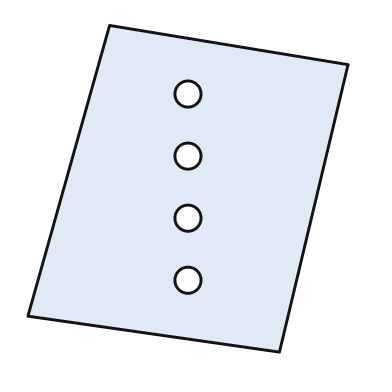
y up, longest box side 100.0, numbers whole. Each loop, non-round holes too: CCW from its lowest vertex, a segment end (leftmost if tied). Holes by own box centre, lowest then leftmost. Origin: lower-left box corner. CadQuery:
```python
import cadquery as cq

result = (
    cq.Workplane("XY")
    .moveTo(77.0, 0.0)
    .lineTo(98.0, 88.0)
    .lineTo(25.0, 100.0)
    .lineTo(0.0, 11.0)
    .close()
    .moveTo(49.0, 22.0)
    .circle(4.0)
    .moveTo(49.0, 41.0)
    .circle(4.0)
    .moveTo(49.0, 60.0)
    .circle(4.0)
    .moveTo(49.0, 79.0)
    .circle(4.0)
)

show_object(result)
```